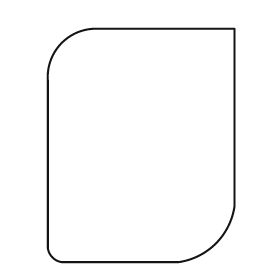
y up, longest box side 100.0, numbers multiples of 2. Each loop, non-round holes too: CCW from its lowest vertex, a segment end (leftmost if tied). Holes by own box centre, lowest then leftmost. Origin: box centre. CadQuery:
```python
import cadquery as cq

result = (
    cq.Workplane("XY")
    .moveTo(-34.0, -50.0)
    .lineTo(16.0, -50.0)
    .threePointArc((32.0, -42.0), (40.0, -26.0))
    .lineTo(40.0, 50.0)
    .lineTo(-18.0, 50.0)
    .threePointArc((-34.0, 44.0), (-40.0, 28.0))
    .lineTo(-40.0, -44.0)
    .threePointArc((-38.0, -48.0), (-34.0, -50.0))
    .close()
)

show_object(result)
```